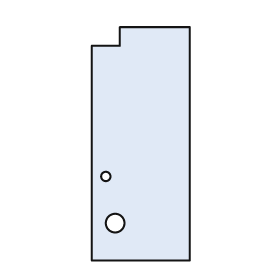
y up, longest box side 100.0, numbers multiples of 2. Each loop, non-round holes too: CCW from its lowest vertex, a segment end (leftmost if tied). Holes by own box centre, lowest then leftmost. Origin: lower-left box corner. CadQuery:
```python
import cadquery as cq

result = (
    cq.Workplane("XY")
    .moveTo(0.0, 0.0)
    .lineTo(42.0, 0.0)
    .lineTo(42.0, 100.0)
    .lineTo(12.0, 100.0)
    .lineTo(12.0, 92.0)
    .lineTo(0.0, 92.0)
    .close()
    .moveTo(10.0, 16.0)
    .circle(4.0)
    .moveTo(6.0, 36.0)
    .circle(2.0)
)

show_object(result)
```